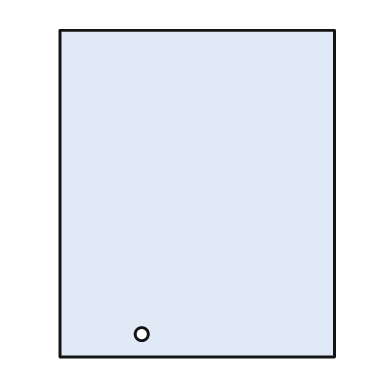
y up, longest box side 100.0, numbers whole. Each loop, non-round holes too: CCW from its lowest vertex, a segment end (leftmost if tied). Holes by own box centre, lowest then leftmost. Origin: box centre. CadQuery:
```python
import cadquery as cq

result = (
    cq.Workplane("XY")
    .moveTo(-42.0, -50.0)
    .lineTo(42.0, -50.0)
    .lineTo(42.0, 50.0)
    .lineTo(-42.0, 50.0)
    .close()
    .moveTo(-17.0, -43.0)
    .circle(2.0)
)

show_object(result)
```